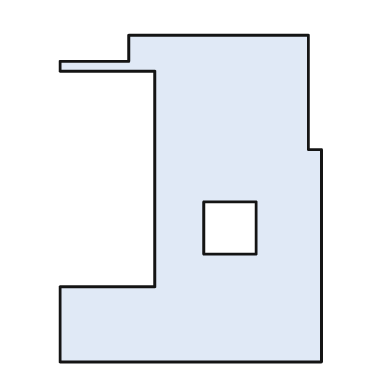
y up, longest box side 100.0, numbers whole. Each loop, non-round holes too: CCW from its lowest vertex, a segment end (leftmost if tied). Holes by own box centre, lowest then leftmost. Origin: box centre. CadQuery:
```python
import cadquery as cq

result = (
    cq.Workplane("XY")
    .moveTo(-40.0, -50.0)
    .lineTo(40.0, -50.0)
    .lineTo(40.0, 15.0)
    .lineTo(36.0, 15.0)
    .lineTo(36.0, 50.0)
    .lineTo(-19.0, 50.0)
    .lineTo(-19.0, 42.0)
    .lineTo(-40.0, 42.0)
    .lineTo(-40.0, 39.0)
    .lineTo(-11.0, 39.0)
    .lineTo(-11.0, -27.0)
    .lineTo(-40.0, -27.0)
    .close()
    .moveTo(4.0, -17.0)
    .lineTo(20.0, -17.0)
    .lineTo(20.0, -1.0)
    .lineTo(4.0, -1.0)
    .close()
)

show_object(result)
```